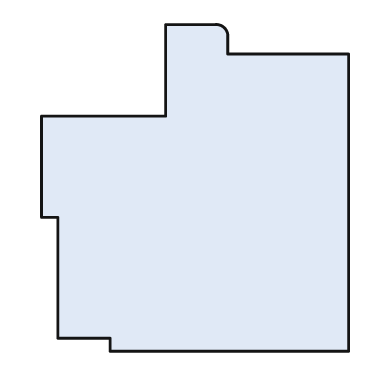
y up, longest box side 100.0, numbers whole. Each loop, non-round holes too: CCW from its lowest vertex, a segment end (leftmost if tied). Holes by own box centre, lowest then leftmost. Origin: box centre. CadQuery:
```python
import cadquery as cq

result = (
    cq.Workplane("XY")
    .moveTo(-26.0, -50.0)
    .lineTo(47.0, -50.0)
    .lineTo(47.0, 41.0)
    .lineTo(10.0, 41.0)
    .lineTo(10.0, 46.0)
    .threePointArc((9.0, 49.0), (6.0, 50.0))
    .lineTo(-9.0, 50.0)
    .lineTo(-9.0, 22.0)
    .lineTo(-47.0, 22.0)
    .lineTo(-47.0, -9.0)
    .lineTo(-42.0, -9.0)
    .lineTo(-42.0, -46.0)
    .lineTo(-26.0, -46.0)
    .close()
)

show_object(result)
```